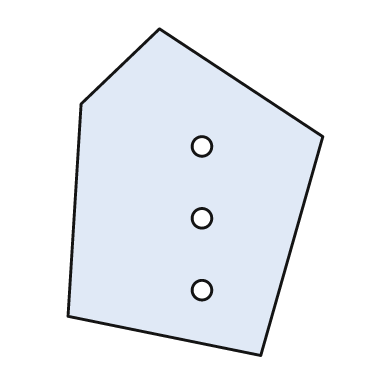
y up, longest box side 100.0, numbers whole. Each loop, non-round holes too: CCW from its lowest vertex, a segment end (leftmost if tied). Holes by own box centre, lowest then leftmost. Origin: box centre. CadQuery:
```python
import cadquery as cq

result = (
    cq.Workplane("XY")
    .moveTo(20.0, -50.0)
    .lineTo(39.0, 17.0)
    .lineTo(-11.0, 50.0)
    .lineTo(-35.0, 27.0)
    .lineTo(-39.0, -38.0)
    .close()
    .moveTo(2.0, -30.0)
    .circle(3.0)
    .moveTo(2.0, -8.0)
    .circle(3.0)
    .moveTo(2.0, 14.0)
    .circle(3.0)
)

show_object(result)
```